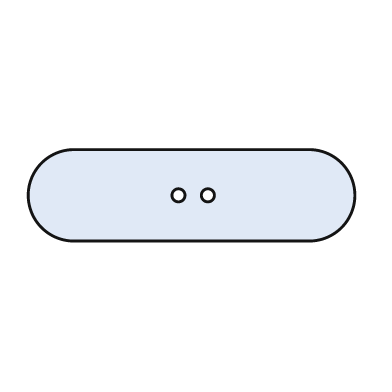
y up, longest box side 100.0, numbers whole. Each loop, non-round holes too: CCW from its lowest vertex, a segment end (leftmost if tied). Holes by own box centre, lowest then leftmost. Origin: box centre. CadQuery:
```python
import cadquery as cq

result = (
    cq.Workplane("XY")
    .moveTo(-36.0, -14.0)
    .lineTo(36.0, -14.0)
    .threePointArc((50.0, 0.0), (36.0, 14.0))
    .lineTo(-36.0, 14.0)
    .threePointArc((-50.0, 0.0), (-36.0, -14.0))
    .close()
    .moveTo(-4.0, 0.0)
    .circle(2.0)
    .moveTo(5.0, 0.0)
    .circle(2.0)
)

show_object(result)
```